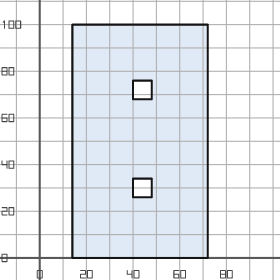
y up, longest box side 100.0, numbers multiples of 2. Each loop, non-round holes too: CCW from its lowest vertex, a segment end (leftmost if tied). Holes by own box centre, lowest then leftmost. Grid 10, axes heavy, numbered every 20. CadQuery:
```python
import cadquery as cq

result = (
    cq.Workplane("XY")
    .moveTo(14.0, 0.0)
    .lineTo(72.0, 0.0)
    .lineTo(72.0, 100.0)
    .lineTo(14.0, 100.0)
    .close()
    .moveTo(40.0, 26.0)
    .lineTo(48.0, 26.0)
    .lineTo(48.0, 34.0)
    .lineTo(40.0, 34.0)
    .close()
    .moveTo(40.0, 68.0)
    .lineTo(48.0, 68.0)
    .lineTo(48.0, 76.0)
    .lineTo(40.0, 76.0)
    .close()
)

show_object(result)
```